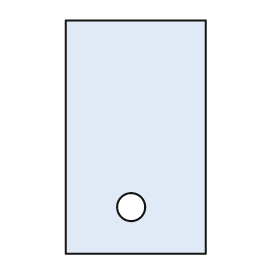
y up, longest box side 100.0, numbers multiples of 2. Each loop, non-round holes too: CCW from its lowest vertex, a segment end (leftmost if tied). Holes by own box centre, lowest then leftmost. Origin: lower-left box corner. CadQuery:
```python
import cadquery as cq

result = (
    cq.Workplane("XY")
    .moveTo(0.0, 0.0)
    .lineTo(60.0, 0.0)
    .lineTo(60.0, 100.0)
    .lineTo(0.0, 100.0)
    .close()
    .moveTo(28.0, 20.0)
    .circle(6.0)
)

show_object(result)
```